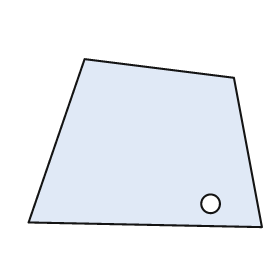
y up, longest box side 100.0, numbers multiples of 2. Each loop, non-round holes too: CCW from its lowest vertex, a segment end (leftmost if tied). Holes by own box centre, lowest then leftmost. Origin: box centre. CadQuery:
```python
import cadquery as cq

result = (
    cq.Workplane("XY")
    .moveTo(50.0, -36.0)
    .lineTo(38.0, 28.0)
    .lineTo(-26.0, 36.0)
    .lineTo(-50.0, -34.0)
    .close()
    .moveTo(28.0, -26.0)
    .circle(4.0)
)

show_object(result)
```